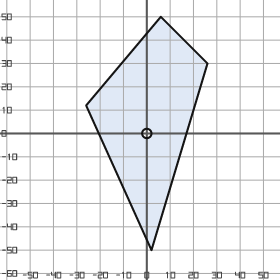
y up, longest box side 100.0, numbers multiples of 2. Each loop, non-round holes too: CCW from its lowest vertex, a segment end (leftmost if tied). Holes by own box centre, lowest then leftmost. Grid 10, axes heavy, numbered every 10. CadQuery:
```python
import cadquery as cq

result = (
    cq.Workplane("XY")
    .moveTo(2.0, -50.0)
    .lineTo(26.0, 30.0)
    .lineTo(6.0, 50.0)
    .lineTo(-26.0, 12.0)
    .close()
    .moveTo(0.0, 0.0)
    .circle(2.0)
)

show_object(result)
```